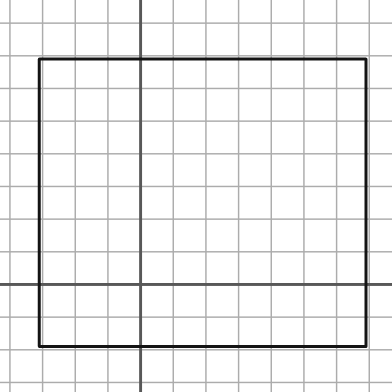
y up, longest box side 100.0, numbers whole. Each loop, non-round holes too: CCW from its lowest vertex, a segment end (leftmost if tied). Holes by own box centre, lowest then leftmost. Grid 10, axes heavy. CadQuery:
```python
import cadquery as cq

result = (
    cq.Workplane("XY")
    .moveTo(-31.0, -19.0)
    .lineTo(69.0, -19.0)
    .lineTo(69.0, 69.0)
    .lineTo(-31.0, 69.0)
    .close()
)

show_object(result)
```